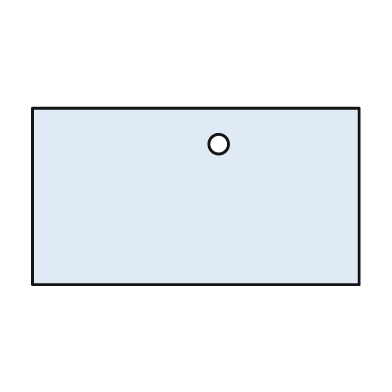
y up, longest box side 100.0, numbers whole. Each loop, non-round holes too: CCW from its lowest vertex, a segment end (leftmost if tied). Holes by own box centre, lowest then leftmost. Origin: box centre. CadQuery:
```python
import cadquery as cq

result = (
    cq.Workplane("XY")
    .moveTo(-50.0, -27.0)
    .lineTo(50.0, -27.0)
    .lineTo(50.0, 27.0)
    .lineTo(-50.0, 27.0)
    .close()
    .moveTo(7.0, 16.0)
    .circle(3.0)
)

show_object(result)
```